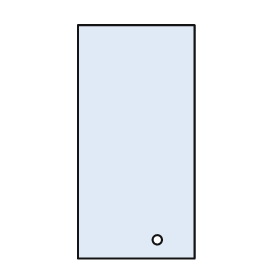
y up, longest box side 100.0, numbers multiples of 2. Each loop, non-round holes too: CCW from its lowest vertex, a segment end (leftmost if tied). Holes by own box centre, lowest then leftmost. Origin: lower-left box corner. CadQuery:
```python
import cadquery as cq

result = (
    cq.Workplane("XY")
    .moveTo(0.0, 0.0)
    .lineTo(50.0, 0.0)
    .lineTo(50.0, 100.0)
    .lineTo(0.0, 100.0)
    .close()
    .moveTo(34.0, 8.0)
    .circle(2.0)
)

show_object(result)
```